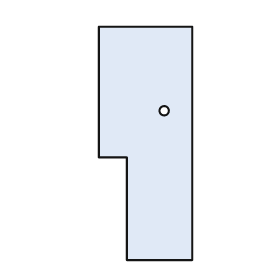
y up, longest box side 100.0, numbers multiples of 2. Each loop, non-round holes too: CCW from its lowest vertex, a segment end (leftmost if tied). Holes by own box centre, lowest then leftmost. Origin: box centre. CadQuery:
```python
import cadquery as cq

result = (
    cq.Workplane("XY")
    .moveTo(-8.0, -50.0)
    .lineTo(20.0, -50.0)
    .lineTo(20.0, 50.0)
    .lineTo(-20.0, 50.0)
    .lineTo(-20.0, -6.0)
    .lineTo(-8.0, -6.0)
    .close()
    .moveTo(8.0, 14.0)
    .circle(2.0)
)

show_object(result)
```